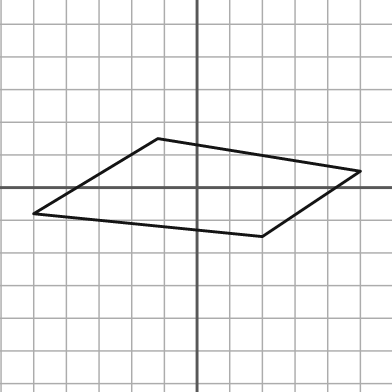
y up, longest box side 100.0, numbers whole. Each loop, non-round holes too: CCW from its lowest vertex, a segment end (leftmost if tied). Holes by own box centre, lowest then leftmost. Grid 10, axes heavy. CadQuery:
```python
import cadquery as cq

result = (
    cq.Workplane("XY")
    .moveTo(20.0, -15.0)
    .lineTo(50.0, 5.0)
    .lineTo(-12.0, 15.0)
    .lineTo(-50.0, -8.0)
    .close()
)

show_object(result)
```